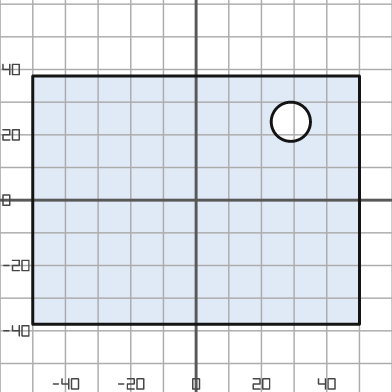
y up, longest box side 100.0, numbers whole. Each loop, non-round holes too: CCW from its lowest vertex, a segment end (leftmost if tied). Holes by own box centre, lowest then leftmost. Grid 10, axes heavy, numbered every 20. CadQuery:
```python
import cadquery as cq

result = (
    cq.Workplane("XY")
    .moveTo(-50.0, -38.0)
    .lineTo(50.0, -38.0)
    .lineTo(50.0, 38.0)
    .lineTo(-50.0, 38.0)
    .close()
    .moveTo(29.0, 24.0)
    .circle(6.0)
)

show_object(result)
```